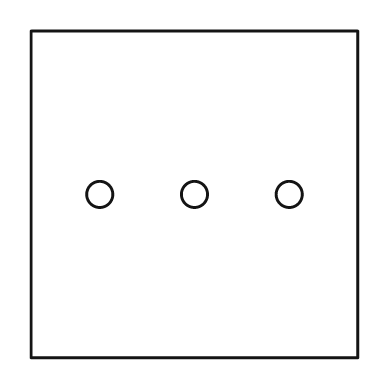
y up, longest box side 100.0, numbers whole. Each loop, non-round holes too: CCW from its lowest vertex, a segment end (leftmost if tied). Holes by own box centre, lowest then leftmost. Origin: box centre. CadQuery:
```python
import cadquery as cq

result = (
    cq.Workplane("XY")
    .moveTo(-50.0, -50.0)
    .lineTo(50.0, -50.0)
    .lineTo(50.0, 50.0)
    .lineTo(-50.0, 50.0)
    .close()
    .moveTo(-29.0, 0.0)
    .circle(4.0)
    .moveTo(0.0, 0.0)
    .circle(4.0)
    .moveTo(29.0, 0.0)
    .circle(4.0)
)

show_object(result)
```